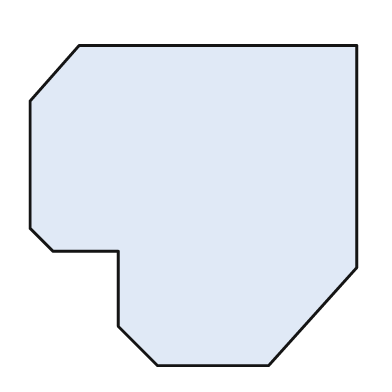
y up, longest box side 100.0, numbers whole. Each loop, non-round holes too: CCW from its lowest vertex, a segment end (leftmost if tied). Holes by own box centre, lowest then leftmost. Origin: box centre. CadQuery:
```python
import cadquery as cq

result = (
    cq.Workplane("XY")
    .moveTo(-11.0, -49.0)
    .lineTo(23.0, -49.0)
    .lineTo(50.0, -19.0)
    .lineTo(50.0, 49.0)
    .lineTo(-35.0, 49.0)
    .lineTo(-50.0, 32.0)
    .lineTo(-50.0, -7.0)
    .lineTo(-43.0, -14.0)
    .lineTo(-23.0, -14.0)
    .lineTo(-23.0, -37.0)
    .close()
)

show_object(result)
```